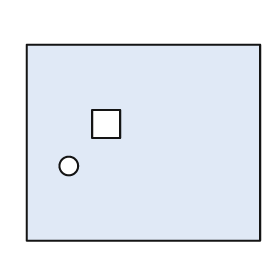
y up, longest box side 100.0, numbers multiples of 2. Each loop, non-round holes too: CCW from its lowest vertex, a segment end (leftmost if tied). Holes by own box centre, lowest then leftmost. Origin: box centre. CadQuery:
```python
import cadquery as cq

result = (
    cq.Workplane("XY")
    .moveTo(-50.0, -42.0)
    .lineTo(50.0, -42.0)
    .lineTo(50.0, 42.0)
    .lineTo(-50.0, 42.0)
    .close()
    .moveTo(-32.0, -10.0)
    .circle(4.0)
    .moveTo(-22.0, 2.0)
    .lineTo(-10.0, 2.0)
    .lineTo(-10.0, 14.0)
    .lineTo(-22.0, 14.0)
    .close()
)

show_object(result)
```